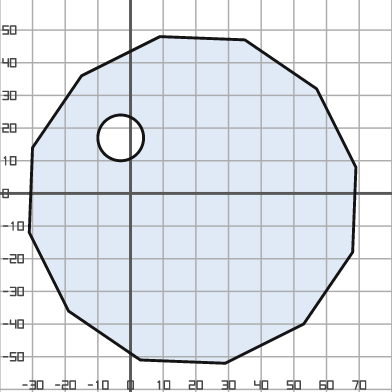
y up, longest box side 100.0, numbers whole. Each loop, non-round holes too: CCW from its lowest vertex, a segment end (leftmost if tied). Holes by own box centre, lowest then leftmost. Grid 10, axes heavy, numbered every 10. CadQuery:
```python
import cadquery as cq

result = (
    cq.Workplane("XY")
    .moveTo(29.0, -52.0)
    .lineTo(53.0, -40.0)
    .lineTo(68.0, -18.0)
    .lineTo(69.0, 8.0)
    .lineTo(57.0, 32.0)
    .lineTo(35.0, 47.0)
    .lineTo(9.0, 48.0)
    .lineTo(-15.0, 36.0)
    .lineTo(-30.0, 14.0)
    .lineTo(-31.0, -12.0)
    .lineTo(-19.0, -36.0)
    .lineTo(3.0, -51.0)
    .close()
    .moveTo(-3.0, 17.0)
    .circle(7.0)
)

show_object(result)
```